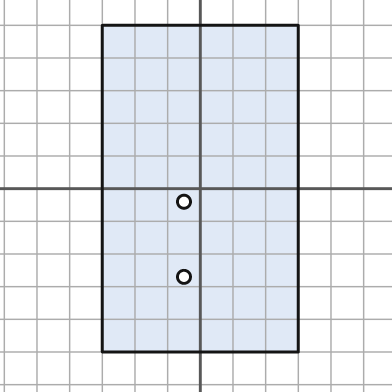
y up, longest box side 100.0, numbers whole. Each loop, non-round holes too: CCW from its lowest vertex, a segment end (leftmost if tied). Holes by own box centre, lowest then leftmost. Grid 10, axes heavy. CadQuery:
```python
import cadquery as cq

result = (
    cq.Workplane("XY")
    .moveTo(-30.0, -50.0)
    .lineTo(30.0, -50.0)
    .lineTo(30.0, 50.0)
    .lineTo(-30.0, 50.0)
    .close()
    .moveTo(-5.0, -27.0)
    .circle(2.0)
    .moveTo(-5.0, -4.0)
    .circle(2.0)
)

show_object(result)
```